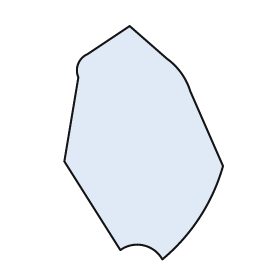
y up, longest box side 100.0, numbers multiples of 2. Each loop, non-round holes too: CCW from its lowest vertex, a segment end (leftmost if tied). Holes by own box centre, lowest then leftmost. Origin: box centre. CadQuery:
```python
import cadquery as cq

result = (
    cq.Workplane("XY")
    .moveTo(8.0, -50.0)
    .threePointArc((24.0, -32.0), (34.0, -10.0))
    .lineTo(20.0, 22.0)
    .threePointArc((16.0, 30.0), (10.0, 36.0))
    .lineTo(-6.0, 50.0)
    .lineTo(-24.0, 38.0)
    .threePointArc((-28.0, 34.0), (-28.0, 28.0))
    .lineTo(-34.0, -8.0)
    .lineTo(-10.0, -46.0)
    .threePointArc((0.0, -44.0), (8.0, -50.0))
    .close()
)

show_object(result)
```